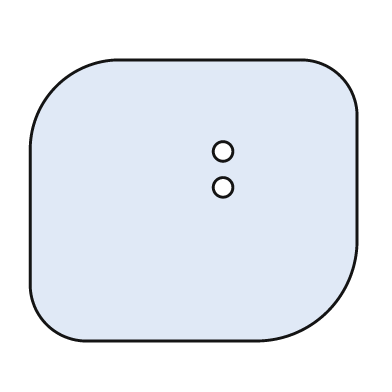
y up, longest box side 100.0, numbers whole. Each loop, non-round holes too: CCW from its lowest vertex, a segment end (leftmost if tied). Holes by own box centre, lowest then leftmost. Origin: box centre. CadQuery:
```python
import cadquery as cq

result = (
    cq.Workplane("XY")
    .moveTo(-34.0, -43.0)
    .lineTo(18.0, -43.0)
    .threePointArc((41.0, -34.0), (50.0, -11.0))
    .lineTo(50.0, 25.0)
    .threePointArc((45.0, 38.0), (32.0, 43.0))
    .lineTo(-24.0, 43.0)
    .threePointArc((-42.0, 35.0), (-50.0, 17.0))
    .lineTo(-50.0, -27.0)
    .threePointArc((-45.0, -38.0), (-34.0, -43.0))
    .close()
    .moveTo(9.0, 4.0)
    .circle(3.0)
    .moveTo(9.0, 15.0)
    .circle(3.0)
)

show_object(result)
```